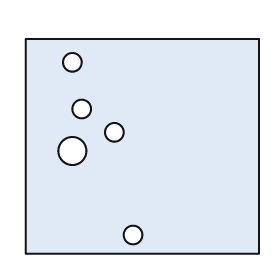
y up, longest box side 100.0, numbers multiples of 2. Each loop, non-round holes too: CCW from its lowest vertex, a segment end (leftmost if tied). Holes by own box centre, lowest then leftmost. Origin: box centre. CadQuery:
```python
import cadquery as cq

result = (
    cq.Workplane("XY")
    .moveTo(-50.0, -46.0)
    .lineTo(50.0, -46.0)
    .lineTo(50.0, 46.0)
    .lineTo(-50.0, 46.0)
    .close()
    .moveTo(-4.0, -38.0)
    .circle(4.0)
    .moveTo(-30.0, -2.0)
    .circle(6.0)
    .moveTo(-12.0, 6.0)
    .circle(4.0)
    .moveTo(-26.0, 16.0)
    .circle(4.0)
    .moveTo(-30.0, 36.0)
    .circle(4.0)
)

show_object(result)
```